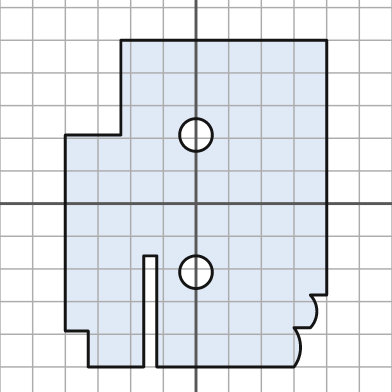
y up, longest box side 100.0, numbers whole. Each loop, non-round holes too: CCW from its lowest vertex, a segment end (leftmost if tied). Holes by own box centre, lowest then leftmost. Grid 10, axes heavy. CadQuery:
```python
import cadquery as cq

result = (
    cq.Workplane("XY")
    .moveTo(-33.0, -50.0)
    .lineTo(-16.0, -50.0)
    .lineTo(-16.0, -16.0)
    .lineTo(-12.0, -16.0)
    .lineTo(-12.0, -50.0)
    .lineTo(30.0, -50.0)
    .threePointArc((32.0, -44.0), (30.0, -38.0))
    .lineTo(35.0, -38.0)
    .threePointArc((37.0, -33.0), (35.0, -28.0))
    .lineTo(40.0, -28.0)
    .lineTo(40.0, 50.0)
    .lineTo(-23.0, 50.0)
    .lineTo(-23.0, 21.0)
    .lineTo(-40.0, 21.0)
    .lineTo(-40.0, -39.0)
    .lineTo(-33.0, -39.0)
    .close()
    .moveTo(0.0, -21.0)
    .circle(5.0)
    .moveTo(0.0, 21.0)
    .circle(5.0)
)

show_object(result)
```